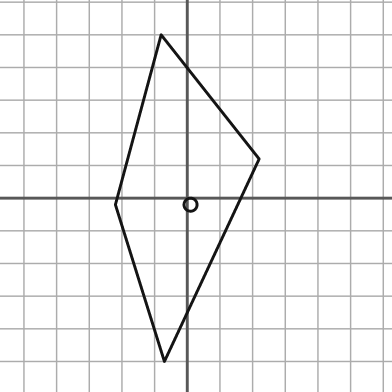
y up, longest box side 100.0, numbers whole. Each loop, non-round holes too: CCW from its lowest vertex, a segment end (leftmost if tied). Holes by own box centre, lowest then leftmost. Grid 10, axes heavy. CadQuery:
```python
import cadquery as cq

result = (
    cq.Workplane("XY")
    .moveTo(-7.0, -50.0)
    .lineTo(22.0, 12.0)
    .lineTo(-8.0, 50.0)
    .lineTo(-22.0, -2.0)
    .close()
    .moveTo(1.0, -2.0)
    .circle(2.0)
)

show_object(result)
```